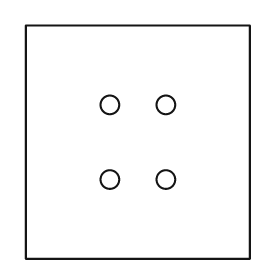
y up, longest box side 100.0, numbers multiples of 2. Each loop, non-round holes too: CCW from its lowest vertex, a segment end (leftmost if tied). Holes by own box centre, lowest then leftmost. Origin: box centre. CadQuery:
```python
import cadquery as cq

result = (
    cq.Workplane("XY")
    .moveTo(-48.0, -50.0)
    .lineTo(48.0, -50.0)
    .lineTo(48.0, 50.0)
    .lineTo(-48.0, 50.0)
    .close()
    .moveTo(-12.0, -16.0)
    .circle(4.0)
    .moveTo(12.0, -16.0)
    .circle(4.0)
    .moveTo(-12.0, 16.0)
    .circle(4.0)
    .moveTo(12.0, 16.0)
    .circle(4.0)
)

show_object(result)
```